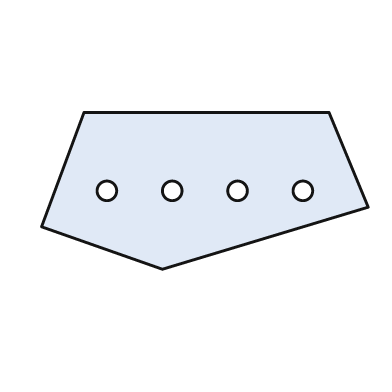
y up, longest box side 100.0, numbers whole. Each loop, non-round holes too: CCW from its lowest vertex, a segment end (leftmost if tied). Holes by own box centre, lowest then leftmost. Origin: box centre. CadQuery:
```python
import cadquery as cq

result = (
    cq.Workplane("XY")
    .moveTo(-13.0, -24.0)
    .lineTo(50.0, -5.0)
    .lineTo(38.0, 24.0)
    .lineTo(-37.0, 24.0)
    .lineTo(-50.0, -11.0)
    .close()
    .moveTo(-30.0, 0.0)
    .circle(3.0)
    .moveTo(-10.0, 0.0)
    .circle(3.0)
    .moveTo(10.0, 0.0)
    .circle(3.0)
    .moveTo(30.0, 0.0)
    .circle(3.0)
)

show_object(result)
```